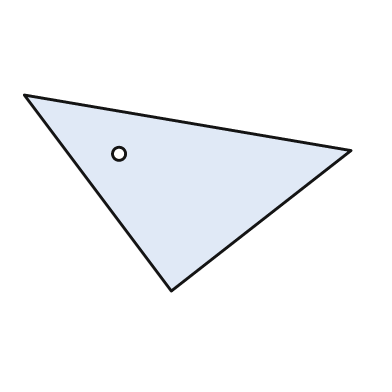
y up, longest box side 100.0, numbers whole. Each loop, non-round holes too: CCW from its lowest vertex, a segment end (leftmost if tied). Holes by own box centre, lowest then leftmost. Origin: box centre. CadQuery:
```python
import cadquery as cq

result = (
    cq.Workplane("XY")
    .moveTo(-5.0, -30.0)
    .lineTo(50.0, 13.0)
    .lineTo(-50.0, 30.0)
    .close()
    .moveTo(-21.0, 12.0)
    .circle(2.0)
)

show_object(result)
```